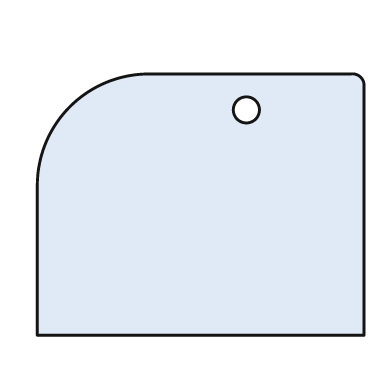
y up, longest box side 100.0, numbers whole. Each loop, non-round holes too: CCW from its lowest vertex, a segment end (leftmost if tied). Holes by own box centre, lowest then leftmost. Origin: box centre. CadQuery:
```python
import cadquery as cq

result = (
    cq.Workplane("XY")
    .moveTo(-50.0, -40.0)
    .lineTo(50.0, -40.0)
    .lineTo(50.0, 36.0)
    .threePointArc((49.0, 39.0), (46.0, 40.0))
    .lineTo(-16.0, 40.0)
    .threePointArc((-40.0, 30.0), (-50.0, 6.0))
    .close()
    .moveTo(14.0, 29.0)
    .circle(4.0)
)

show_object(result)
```